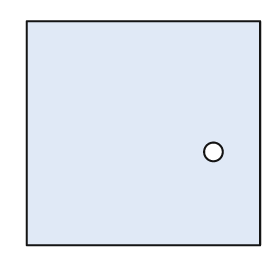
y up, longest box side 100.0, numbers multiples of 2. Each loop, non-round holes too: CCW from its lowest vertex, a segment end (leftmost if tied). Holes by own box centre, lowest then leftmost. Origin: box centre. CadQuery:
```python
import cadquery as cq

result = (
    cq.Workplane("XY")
    .moveTo(-50.0, -48.0)
    .lineTo(50.0, -48.0)
    .lineTo(50.0, 48.0)
    .lineTo(-50.0, 48.0)
    .close()
    .moveTo(30.0, -8.0)
    .circle(4.0)
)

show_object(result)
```